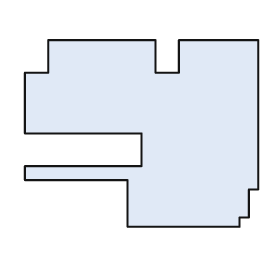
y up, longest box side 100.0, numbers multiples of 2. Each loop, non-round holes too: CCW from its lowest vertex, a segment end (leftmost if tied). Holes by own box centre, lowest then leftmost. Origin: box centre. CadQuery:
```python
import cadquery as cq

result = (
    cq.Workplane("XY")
    .moveTo(-6.0, -40.0)
    .lineTo(42.0, -40.0)
    .lineTo(42.0, -36.0)
    .lineTo(46.0, -36.0)
    .lineTo(46.0, -24.0)
    .lineTo(50.0, -24.0)
    .lineTo(50.0, 40.0)
    .lineTo(16.0, 40.0)
    .lineTo(16.0, 26.0)
    .lineTo(6.0, 26.0)
    .lineTo(6.0, 40.0)
    .lineTo(-40.0, 40.0)
    .lineTo(-40.0, 26.0)
    .lineTo(-50.0, 26.0)
    .lineTo(-50.0, 0.0)
    .lineTo(0.0, 0.0)
    .lineTo(0.0, -14.0)
    .lineTo(-50.0, -14.0)
    .lineTo(-50.0, -20.0)
    .lineTo(-6.0, -20.0)
    .close()
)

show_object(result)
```